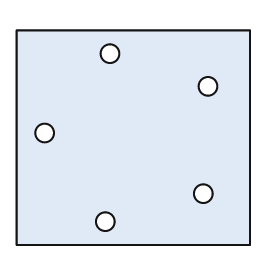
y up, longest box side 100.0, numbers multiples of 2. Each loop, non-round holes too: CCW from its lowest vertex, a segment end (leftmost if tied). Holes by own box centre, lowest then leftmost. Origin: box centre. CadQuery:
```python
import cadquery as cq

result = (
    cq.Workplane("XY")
    .moveTo(-50.0, -46.0)
    .lineTo(50.0, -46.0)
    .lineTo(50.0, 46.0)
    .lineTo(-50.0, 46.0)
    .close()
    .moveTo(-12.0, -36.0)
    .circle(4.0)
    .moveTo(30.0, -24.0)
    .circle(4.0)
    .moveTo(-38.0, 2.0)
    .circle(4.0)
    .moveTo(32.0, 22.0)
    .circle(4.0)
    .moveTo(-10.0, 36.0)
    .circle(4.0)
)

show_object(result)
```